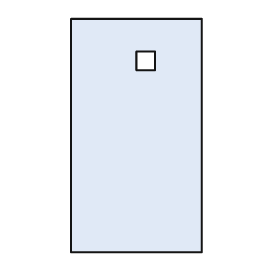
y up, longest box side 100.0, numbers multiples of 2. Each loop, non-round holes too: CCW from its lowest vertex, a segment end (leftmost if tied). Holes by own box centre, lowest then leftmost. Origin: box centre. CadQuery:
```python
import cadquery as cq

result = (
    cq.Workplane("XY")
    .moveTo(-28.0, -50.0)
    .lineTo(28.0, -50.0)
    .lineTo(28.0, 50.0)
    .lineTo(-28.0, 50.0)
    .close()
    .moveTo(0.0, 28.0)
    .lineTo(8.0, 28.0)
    .lineTo(8.0, 36.0)
    .lineTo(0.0, 36.0)
    .close()
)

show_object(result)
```